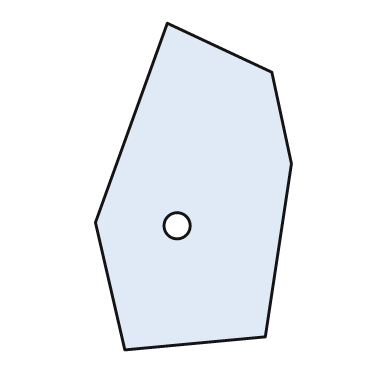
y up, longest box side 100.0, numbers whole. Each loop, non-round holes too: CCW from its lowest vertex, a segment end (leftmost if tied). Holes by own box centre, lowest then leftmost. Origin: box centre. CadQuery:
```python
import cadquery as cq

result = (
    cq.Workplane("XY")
    .moveTo(-21.0, -50.0)
    .lineTo(22.0, -46.0)
    .lineTo(30.0, 7.0)
    .lineTo(24.0, 35.0)
    .lineTo(-8.0, 50.0)
    .lineTo(-30.0, -11.0)
    .close()
    .moveTo(-5.0, -12.0)
    .circle(4.0)
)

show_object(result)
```